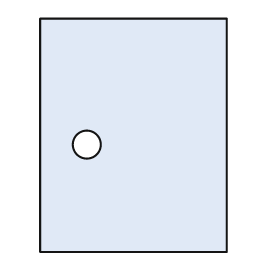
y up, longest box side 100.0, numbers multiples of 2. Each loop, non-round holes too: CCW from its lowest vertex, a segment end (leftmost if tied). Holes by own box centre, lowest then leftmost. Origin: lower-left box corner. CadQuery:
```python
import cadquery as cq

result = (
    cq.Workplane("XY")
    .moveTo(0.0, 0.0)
    .lineTo(80.0, 0.0)
    .lineTo(80.0, 100.0)
    .lineTo(0.0, 100.0)
    .close()
    .moveTo(20.0, 46.0)
    .circle(6.0)
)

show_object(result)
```